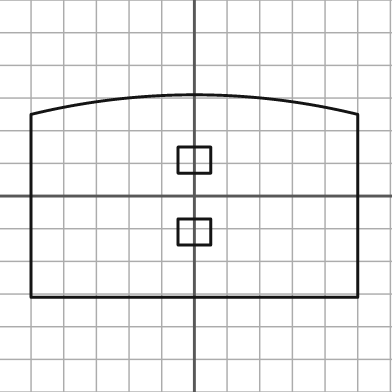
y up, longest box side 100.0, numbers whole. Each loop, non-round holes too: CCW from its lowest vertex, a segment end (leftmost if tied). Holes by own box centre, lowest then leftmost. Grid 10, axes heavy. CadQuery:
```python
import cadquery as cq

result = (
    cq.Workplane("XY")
    .moveTo(-50.0, -31.0)
    .lineTo(50.0, -31.0)
    .lineTo(50.0, 25.0)
    .threePointArc((0.0, 31.0), (-50.0, 25.0))
    .close()
    .moveTo(-5.0, -15.0)
    .lineTo(5.0, -15.0)
    .lineTo(5.0, -7.0)
    .lineTo(-5.0, -7.0)
    .close()
    .moveTo(-5.0, 7.0)
    .lineTo(5.0, 7.0)
    .lineTo(5.0, 15.0)
    .lineTo(-5.0, 15.0)
    .close()
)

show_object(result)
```